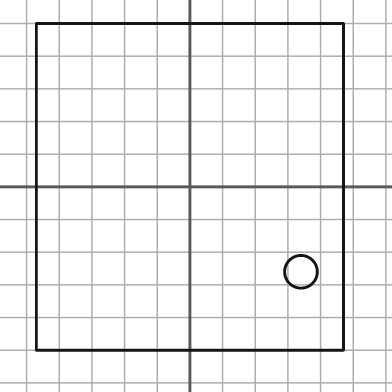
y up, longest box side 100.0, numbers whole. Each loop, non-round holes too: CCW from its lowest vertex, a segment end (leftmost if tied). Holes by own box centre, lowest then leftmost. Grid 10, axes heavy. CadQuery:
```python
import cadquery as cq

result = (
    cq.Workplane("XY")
    .moveTo(-47.0, -50.0)
    .lineTo(47.0, -50.0)
    .lineTo(47.0, 50.0)
    .lineTo(-47.0, 50.0)
    .close()
    .moveTo(34.0, -26.0)
    .circle(5.0)
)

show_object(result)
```